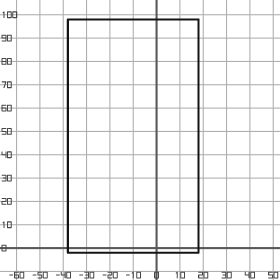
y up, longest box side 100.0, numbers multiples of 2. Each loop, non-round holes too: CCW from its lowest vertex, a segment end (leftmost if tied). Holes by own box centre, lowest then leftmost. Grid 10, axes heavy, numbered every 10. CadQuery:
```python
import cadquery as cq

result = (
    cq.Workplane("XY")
    .moveTo(-38.0, -2.0)
    .lineTo(18.0, -2.0)
    .lineTo(18.0, 98.0)
    .lineTo(-38.0, 98.0)
    .close()
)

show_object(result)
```